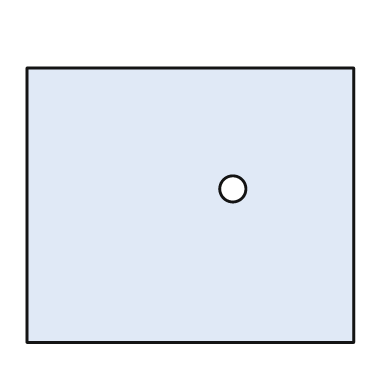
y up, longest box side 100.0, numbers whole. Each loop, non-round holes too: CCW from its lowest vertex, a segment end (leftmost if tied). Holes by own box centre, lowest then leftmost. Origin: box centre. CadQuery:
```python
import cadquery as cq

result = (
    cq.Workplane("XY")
    .moveTo(-50.0, -42.0)
    .lineTo(50.0, -42.0)
    .lineTo(50.0, 42.0)
    .lineTo(-50.0, 42.0)
    .close()
    .moveTo(13.0, 5.0)
    .circle(4.0)
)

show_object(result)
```